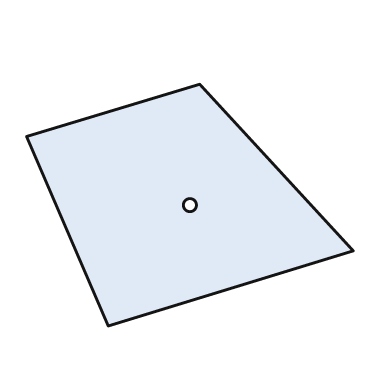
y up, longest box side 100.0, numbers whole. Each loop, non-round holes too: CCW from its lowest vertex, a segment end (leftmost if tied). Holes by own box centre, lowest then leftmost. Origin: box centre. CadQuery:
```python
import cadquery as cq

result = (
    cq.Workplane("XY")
    .moveTo(-25.0, -37.0)
    .lineTo(50.0, -14.0)
    .lineTo(3.0, 37.0)
    .lineTo(-50.0, 21.0)
    .close()
    .moveTo(0.0, 0.0)
    .circle(2.0)
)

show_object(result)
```